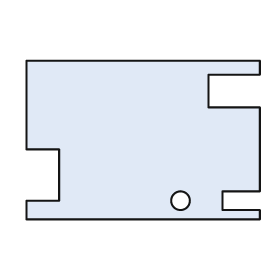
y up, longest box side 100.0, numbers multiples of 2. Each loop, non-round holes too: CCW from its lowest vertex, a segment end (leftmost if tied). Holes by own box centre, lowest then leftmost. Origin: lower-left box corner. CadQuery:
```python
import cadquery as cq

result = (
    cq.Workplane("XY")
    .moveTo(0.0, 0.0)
    .lineTo(100.0, 0.0)
    .lineTo(100.0, 4.0)
    .lineTo(84.0, 4.0)
    .lineTo(84.0, 12.0)
    .lineTo(100.0, 12.0)
    .lineTo(100.0, 48.0)
    .lineTo(78.0, 48.0)
    .lineTo(78.0, 62.0)
    .lineTo(100.0, 62.0)
    .lineTo(100.0, 68.0)
    .lineTo(0.0, 68.0)
    .lineTo(0.0, 30.0)
    .lineTo(14.0, 30.0)
    .lineTo(14.0, 8.0)
    .lineTo(0.0, 8.0)
    .close()
    .moveTo(66.0, 8.0)
    .circle(4.0)
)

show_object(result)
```